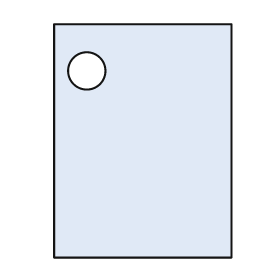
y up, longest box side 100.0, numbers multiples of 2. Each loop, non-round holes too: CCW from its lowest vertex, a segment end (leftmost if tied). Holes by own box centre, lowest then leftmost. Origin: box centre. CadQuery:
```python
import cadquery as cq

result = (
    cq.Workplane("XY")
    .moveTo(-38.0, -50.0)
    .lineTo(38.0, -50.0)
    .lineTo(38.0, 50.0)
    .lineTo(-38.0, 50.0)
    .close()
    .moveTo(-24.0, 30.0)
    .circle(8.0)
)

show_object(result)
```